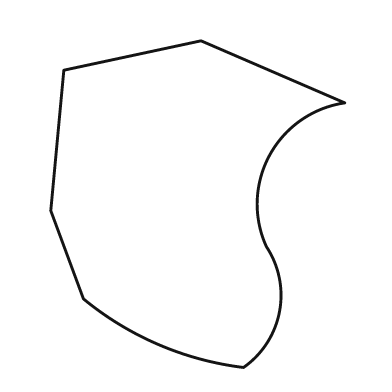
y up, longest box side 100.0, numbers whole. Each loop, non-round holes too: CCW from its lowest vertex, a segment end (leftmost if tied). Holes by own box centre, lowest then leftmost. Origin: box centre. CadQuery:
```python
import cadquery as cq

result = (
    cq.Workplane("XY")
    .moveTo(14.0, -50.0)
    .threePointArc((25.0, -33.0), (21.0, -13.0))
    .threePointArc((22.0, 15.0), (45.0, 31.0))
    .lineTo(1.0, 50.0)
    .lineTo(-41.0, 41.0)
    .lineTo(-45.0, -2.0)
    .lineTo(-35.0, -29.0)
    .threePointArc((-12.0, -43.0), (14.0, -50.0))
    .close()
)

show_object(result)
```